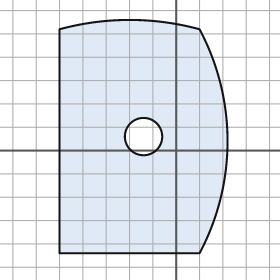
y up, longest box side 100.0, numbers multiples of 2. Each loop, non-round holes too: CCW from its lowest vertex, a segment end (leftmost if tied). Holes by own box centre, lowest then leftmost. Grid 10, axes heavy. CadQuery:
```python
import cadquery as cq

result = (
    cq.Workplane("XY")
    .moveTo(-50.0, -44.0)
    .lineTo(10.0, -44.0)
    .threePointArc((22.0, 4.0), (10.0, 52.0))
    .threePointArc((-20.0, 56.0), (-50.0, 52.0))
    .close()
    .moveTo(-14.0, 6.0)
    .circle(8.0)
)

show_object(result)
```